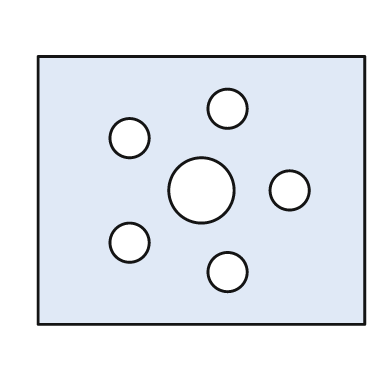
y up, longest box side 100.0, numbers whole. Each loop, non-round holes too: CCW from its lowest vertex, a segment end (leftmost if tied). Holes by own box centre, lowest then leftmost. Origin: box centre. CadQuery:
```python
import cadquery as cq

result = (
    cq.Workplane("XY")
    .moveTo(-50.0, -41.0)
    .lineTo(50.0, -41.0)
    .lineTo(50.0, 41.0)
    .lineTo(-50.0, 41.0)
    .close()
    .moveTo(8.0, -25.0)
    .circle(6.0)
    .moveTo(-22.0, -16.0)
    .circle(6.0)
    .moveTo(0.0, 0.0)
    .circle(10.0)
    .moveTo(27.0, 0.0)
    .circle(6.0)
    .moveTo(-22.0, 16.0)
    .circle(6.0)
    .moveTo(8.0, 25.0)
    .circle(6.0)
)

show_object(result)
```